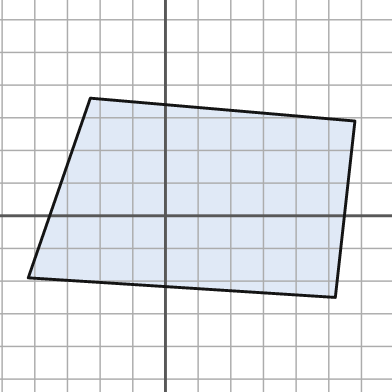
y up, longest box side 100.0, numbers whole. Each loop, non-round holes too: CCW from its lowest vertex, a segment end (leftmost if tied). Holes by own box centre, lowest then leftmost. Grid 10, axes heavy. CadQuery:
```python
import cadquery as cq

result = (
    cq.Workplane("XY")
    .moveTo(52.0, -25.0)
    .lineTo(58.0, 29.0)
    .lineTo(-23.0, 36.0)
    .lineTo(-42.0, -19.0)
    .close()
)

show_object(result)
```